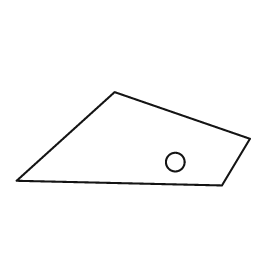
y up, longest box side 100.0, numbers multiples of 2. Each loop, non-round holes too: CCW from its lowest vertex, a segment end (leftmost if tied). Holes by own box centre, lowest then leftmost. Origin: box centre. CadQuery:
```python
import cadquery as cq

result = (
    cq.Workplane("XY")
    .moveTo(38.0, -20.0)
    .lineTo(50.0, 0.0)
    .lineTo(-8.0, 20.0)
    .lineTo(-50.0, -18.0)
    .close()
    .moveTo(18.0, -10.0)
    .circle(4.0)
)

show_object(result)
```